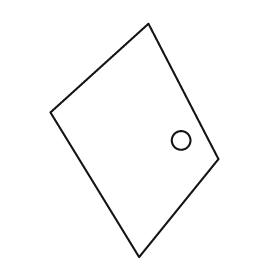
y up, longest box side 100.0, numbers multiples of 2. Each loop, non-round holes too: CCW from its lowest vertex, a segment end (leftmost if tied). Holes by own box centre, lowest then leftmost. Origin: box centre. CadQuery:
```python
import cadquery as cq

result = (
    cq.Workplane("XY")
    .moveTo(2.0, -50.0)
    .lineTo(36.0, -8.0)
    .lineTo(6.0, 50.0)
    .lineTo(-36.0, 12.0)
    .close()
    .moveTo(20.0, 0.0)
    .circle(4.0)
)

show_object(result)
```